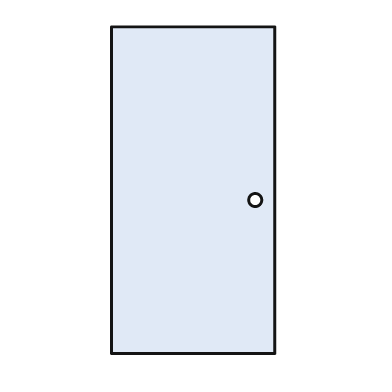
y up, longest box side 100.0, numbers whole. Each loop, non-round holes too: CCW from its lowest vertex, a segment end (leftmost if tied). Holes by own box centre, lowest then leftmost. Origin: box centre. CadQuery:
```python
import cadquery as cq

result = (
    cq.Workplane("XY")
    .moveTo(-25.0, -50.0)
    .lineTo(25.0, -50.0)
    .lineTo(25.0, 50.0)
    .lineTo(-25.0, 50.0)
    .close()
    .moveTo(19.0, -3.0)
    .circle(2.0)
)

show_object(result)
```